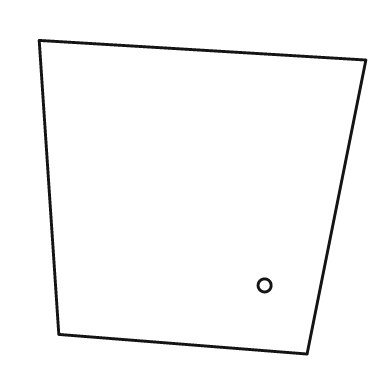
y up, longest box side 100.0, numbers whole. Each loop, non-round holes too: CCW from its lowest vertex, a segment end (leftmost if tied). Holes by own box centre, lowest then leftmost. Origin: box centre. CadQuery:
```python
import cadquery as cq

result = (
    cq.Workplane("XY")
    .moveTo(32.0, -48.0)
    .lineTo(50.0, 42.0)
    .lineTo(-50.0, 48.0)
    .lineTo(-44.0, -42.0)
    .close()
    .moveTo(19.0, -27.0)
    .circle(2.0)
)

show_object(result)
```